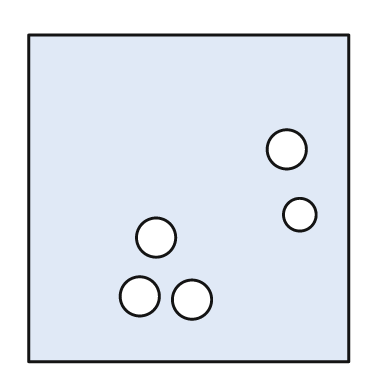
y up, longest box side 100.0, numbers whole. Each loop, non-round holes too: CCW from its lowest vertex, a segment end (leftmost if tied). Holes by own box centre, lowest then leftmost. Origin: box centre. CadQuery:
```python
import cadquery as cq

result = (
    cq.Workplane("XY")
    .moveTo(-49.0, -50.0)
    .lineTo(49.0, -50.0)
    .lineTo(49.0, 50.0)
    .lineTo(-49.0, 50.0)
    .close()
    .moveTo(1.0, -31.0)
    .circle(6.0)
    .moveTo(-15.0, -30.0)
    .circle(6.0)
    .moveTo(-10.0, -12.0)
    .circle(6.0)
    .moveTo(34.0, -5.0)
    .circle(5.0)
    .moveTo(30.0, 15.0)
    .circle(6.0)
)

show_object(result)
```